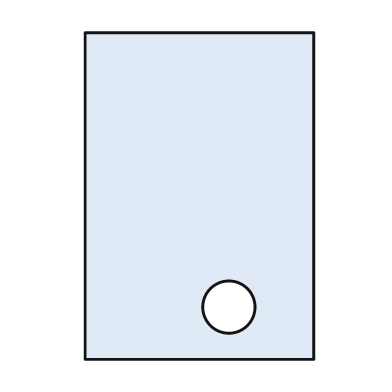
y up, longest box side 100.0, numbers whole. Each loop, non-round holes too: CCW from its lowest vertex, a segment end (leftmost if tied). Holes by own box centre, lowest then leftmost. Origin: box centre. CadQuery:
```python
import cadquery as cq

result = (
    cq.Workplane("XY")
    .moveTo(-35.0, -50.0)
    .lineTo(35.0, -50.0)
    .lineTo(35.0, 50.0)
    .lineTo(-35.0, 50.0)
    .close()
    .moveTo(9.0, -34.0)
    .circle(8.0)
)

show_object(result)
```